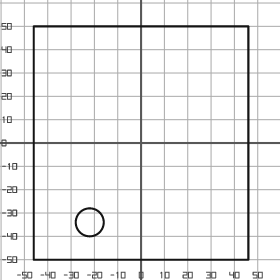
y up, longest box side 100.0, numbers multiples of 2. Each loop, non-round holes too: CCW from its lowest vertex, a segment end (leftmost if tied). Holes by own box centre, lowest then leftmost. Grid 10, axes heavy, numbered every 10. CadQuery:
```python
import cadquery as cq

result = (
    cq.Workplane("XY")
    .moveTo(-46.0, -50.0)
    .lineTo(46.0, -50.0)
    .lineTo(46.0, 50.0)
    .lineTo(-46.0, 50.0)
    .close()
    .moveTo(-22.0, -34.0)
    .circle(6.0)
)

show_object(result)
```